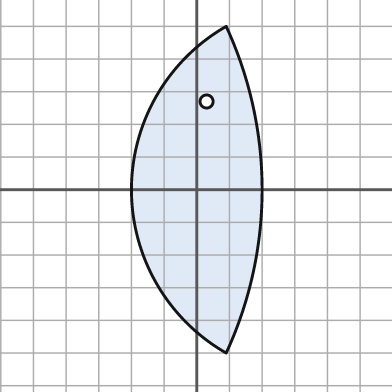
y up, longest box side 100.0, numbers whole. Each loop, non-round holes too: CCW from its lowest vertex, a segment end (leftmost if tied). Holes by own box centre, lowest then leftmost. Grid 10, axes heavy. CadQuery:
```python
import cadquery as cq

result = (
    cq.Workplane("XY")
    .moveTo(9.0, -50.0)
    .threePointArc((20.0, 0.0), (9.0, 50.0))
    .threePointArc((-20.0, 0.0), (9.0, -50.0))
    .close()
    .moveTo(3.0, 27.0)
    .circle(2.0)
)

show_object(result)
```